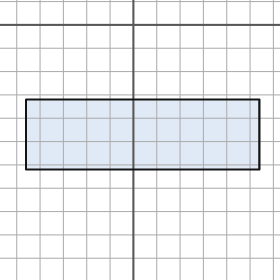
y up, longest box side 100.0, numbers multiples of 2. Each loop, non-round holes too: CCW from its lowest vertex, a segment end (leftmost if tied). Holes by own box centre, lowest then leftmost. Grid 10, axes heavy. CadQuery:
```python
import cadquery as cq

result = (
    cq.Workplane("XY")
    .moveTo(-46.0, -62.0)
    .lineTo(54.0, -62.0)
    .lineTo(54.0, -32.0)
    .lineTo(-46.0, -32.0)
    .close()
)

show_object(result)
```